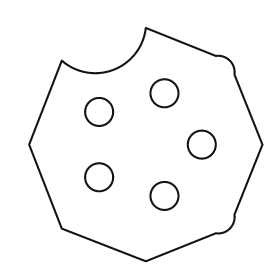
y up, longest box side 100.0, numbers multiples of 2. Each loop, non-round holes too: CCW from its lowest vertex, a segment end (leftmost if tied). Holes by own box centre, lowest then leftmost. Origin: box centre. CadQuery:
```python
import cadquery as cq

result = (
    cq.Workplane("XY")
    .moveTo(0.0, -50.0)
    .lineTo(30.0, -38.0)
    .threePointArc((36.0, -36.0), (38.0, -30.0))
    .lineTo(50.0, 0.0)
    .lineTo(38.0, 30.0)
    .threePointArc((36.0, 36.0), (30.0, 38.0))
    .lineTo(0.0, 50.0)
    .threePointArc((-14.0, 32.0), (-36.0, 36.0))
    .lineTo(-50.0, 0.0)
    .lineTo(-36.0, -36.0)
    .close()
    .moveTo(8.0, -22.0)
    .circle(6.0)
    .moveTo(-20.0, -14.0)
    .circle(6.0)
    .moveTo(24.0, 0.0)
    .circle(6.0)
    .moveTo(-20.0, 14.0)
    .circle(6.0)
    .moveTo(8.0, 22.0)
    .circle(6.0)
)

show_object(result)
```